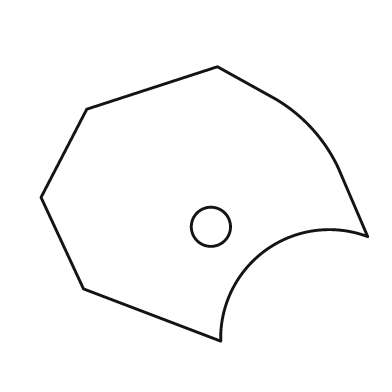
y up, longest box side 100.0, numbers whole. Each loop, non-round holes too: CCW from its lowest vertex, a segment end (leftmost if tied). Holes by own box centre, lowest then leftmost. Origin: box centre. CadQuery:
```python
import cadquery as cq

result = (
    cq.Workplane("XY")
    .moveTo(5.0, -42.0)
    .threePointArc((19.0, -14.0), (50.0, -10.0))
    .lineTo(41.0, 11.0)
    .threePointArc((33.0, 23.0), (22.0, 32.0))
    .lineTo(4.0, 42.0)
    .lineTo(-36.0, 29.0)
    .lineTo(-50.0, 2.0)
    .lineTo(-37.0, -26.0)
    .close()
    .moveTo(2.0, -7.0)
    .circle(6.0)
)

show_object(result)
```